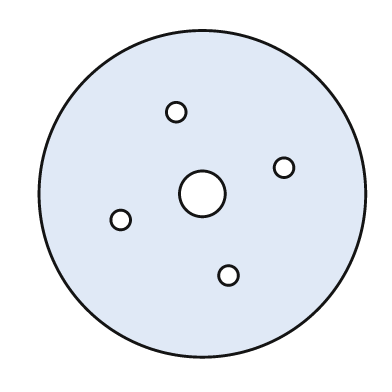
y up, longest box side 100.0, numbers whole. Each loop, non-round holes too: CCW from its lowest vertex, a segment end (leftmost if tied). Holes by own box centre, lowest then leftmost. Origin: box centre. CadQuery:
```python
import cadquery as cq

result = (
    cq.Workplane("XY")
    .moveTo(0.0, 0.0)
    .circle(50.0)
    .moveTo(8.0, -25.0)
    .circle(3.0)
    .moveTo(-25.0, -8.0)
    .circle(3.0)
    .moveTo(0.0, 0.0)
    .circle(7.0)
    .moveTo(25.0, 8.0)
    .circle(3.0)
    .moveTo(-8.0, 25.0)
    .circle(3.0)
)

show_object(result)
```